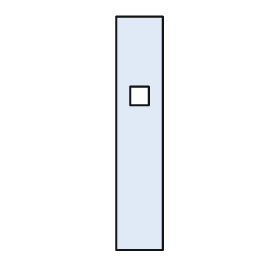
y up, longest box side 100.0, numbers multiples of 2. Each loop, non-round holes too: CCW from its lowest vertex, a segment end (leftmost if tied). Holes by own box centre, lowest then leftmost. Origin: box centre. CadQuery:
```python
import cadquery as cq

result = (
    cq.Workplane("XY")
    .moveTo(-10.0, -50.0)
    .lineTo(10.0, -50.0)
    .lineTo(10.0, 50.0)
    .lineTo(-10.0, 50.0)
    .close()
    .moveTo(-4.0, 12.0)
    .lineTo(4.0, 12.0)
    .lineTo(4.0, 20.0)
    .lineTo(-4.0, 20.0)
    .close()
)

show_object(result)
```